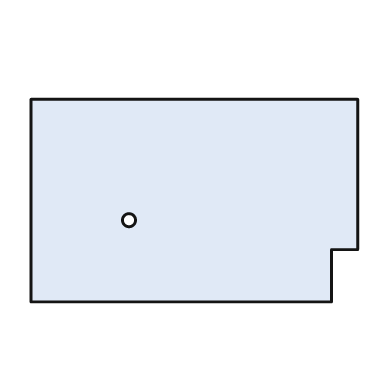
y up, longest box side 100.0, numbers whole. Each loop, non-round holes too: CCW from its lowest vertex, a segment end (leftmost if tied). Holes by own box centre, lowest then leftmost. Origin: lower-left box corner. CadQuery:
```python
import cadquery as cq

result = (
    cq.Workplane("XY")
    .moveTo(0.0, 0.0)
    .lineTo(92.0, 0.0)
    .lineTo(92.0, 16.0)
    .lineTo(100.0, 16.0)
    .lineTo(100.0, 62.0)
    .lineTo(0.0, 62.0)
    .close()
    .moveTo(30.0, 25.0)
    .circle(2.0)
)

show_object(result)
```